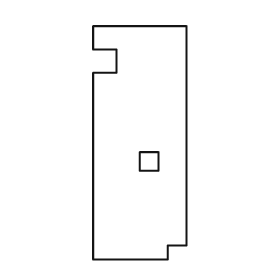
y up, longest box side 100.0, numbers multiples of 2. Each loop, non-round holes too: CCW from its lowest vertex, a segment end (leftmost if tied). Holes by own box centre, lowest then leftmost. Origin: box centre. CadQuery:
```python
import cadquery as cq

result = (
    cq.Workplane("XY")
    .moveTo(-20.0, -50.0)
    .lineTo(12.0, -50.0)
    .lineTo(12.0, -44.0)
    .lineTo(20.0, -44.0)
    .lineTo(20.0, 50.0)
    .lineTo(-20.0, 50.0)
    .lineTo(-20.0, 40.0)
    .lineTo(-10.0, 40.0)
    .lineTo(-10.0, 30.0)
    .lineTo(-20.0, 30.0)
    .close()
    .moveTo(0.0, -12.0)
    .lineTo(8.0, -12.0)
    .lineTo(8.0, -4.0)
    .lineTo(0.0, -4.0)
    .close()
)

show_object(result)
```